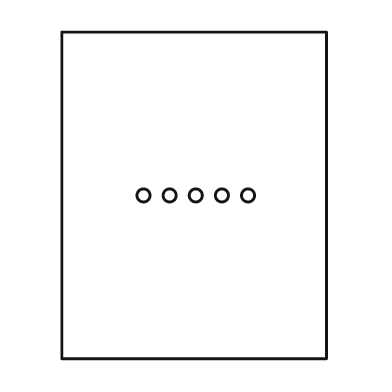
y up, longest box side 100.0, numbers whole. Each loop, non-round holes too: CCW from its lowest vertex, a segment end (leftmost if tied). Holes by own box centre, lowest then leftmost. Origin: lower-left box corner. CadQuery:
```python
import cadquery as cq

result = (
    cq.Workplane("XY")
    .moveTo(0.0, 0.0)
    .lineTo(81.0, 0.0)
    .lineTo(81.0, 100.0)
    .lineTo(0.0, 100.0)
    .close()
    .moveTo(25.0, 50.0)
    .circle(2.0)
    .moveTo(33.0, 50.0)
    .circle(2.0)
    .moveTo(41.0, 50.0)
    .circle(2.0)
    .moveTo(49.0, 50.0)
    .circle(2.0)
    .moveTo(57.0, 50.0)
    .circle(2.0)
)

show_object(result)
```